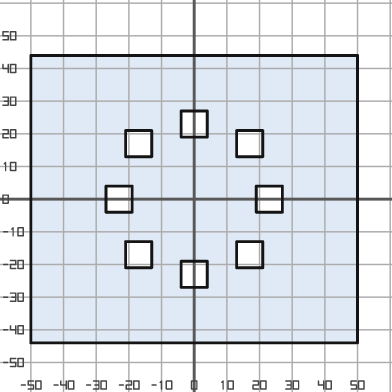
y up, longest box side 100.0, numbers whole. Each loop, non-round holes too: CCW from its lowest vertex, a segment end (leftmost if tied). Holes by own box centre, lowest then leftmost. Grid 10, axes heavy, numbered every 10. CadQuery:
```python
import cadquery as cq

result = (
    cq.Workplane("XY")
    .moveTo(-50.0, -44.0)
    .lineTo(50.0, -44.0)
    .lineTo(50.0, 44.0)
    .lineTo(-50.0, 44.0)
    .close()
    .moveTo(-4.0, -27.0)
    .lineTo(4.0, -27.0)
    .lineTo(4.0, -19.0)
    .lineTo(-4.0, -19.0)
    .close()
    .moveTo(-21.0, -21.0)
    .lineTo(-13.0, -21.0)
    .lineTo(-13.0, -13.0)
    .lineTo(-21.0, -13.0)
    .close()
    .moveTo(13.0, -21.0)
    .lineTo(21.0, -21.0)
    .lineTo(21.0, -13.0)
    .lineTo(13.0, -13.0)
    .close()
    .moveTo(-27.0, -4.0)
    .lineTo(-19.0, -4.0)
    .lineTo(-19.0, 4.0)
    .lineTo(-27.0, 4.0)
    .close()
    .moveTo(19.0, -4.0)
    .lineTo(27.0, -4.0)
    .lineTo(27.0, 4.0)
    .lineTo(19.0, 4.0)
    .close()
    .moveTo(-21.0, 13.0)
    .lineTo(-13.0, 13.0)
    .lineTo(-13.0, 21.0)
    .lineTo(-21.0, 21.0)
    .close()
    .moveTo(13.0, 13.0)
    .lineTo(21.0, 13.0)
    .lineTo(21.0, 21.0)
    .lineTo(13.0, 21.0)
    .close()
    .moveTo(-4.0, 19.0)
    .lineTo(4.0, 19.0)
    .lineTo(4.0, 27.0)
    .lineTo(-4.0, 27.0)
    .close()
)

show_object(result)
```